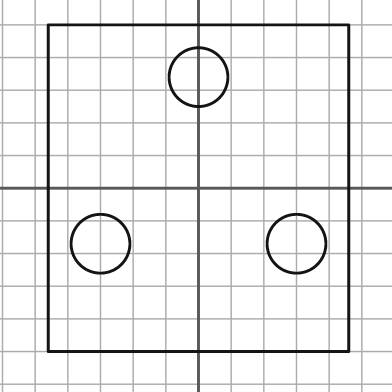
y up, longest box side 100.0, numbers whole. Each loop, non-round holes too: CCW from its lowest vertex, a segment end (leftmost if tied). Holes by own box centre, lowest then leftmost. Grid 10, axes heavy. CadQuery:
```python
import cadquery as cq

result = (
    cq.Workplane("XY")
    .moveTo(-46.0, -50.0)
    .lineTo(46.0, -50.0)
    .lineTo(46.0, 50.0)
    .lineTo(-46.0, 50.0)
    .close()
    .moveTo(-30.0, -17.0)
    .circle(9.0)
    .moveTo(30.0, -17.0)
    .circle(9.0)
    .moveTo(0.0, 34.0)
    .circle(9.0)
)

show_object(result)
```